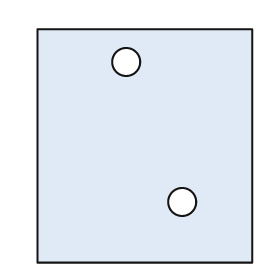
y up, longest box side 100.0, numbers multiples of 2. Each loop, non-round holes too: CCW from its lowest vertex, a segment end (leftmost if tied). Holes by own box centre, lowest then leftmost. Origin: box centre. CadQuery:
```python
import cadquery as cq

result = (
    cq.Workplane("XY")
    .moveTo(-46.0, -50.0)
    .lineTo(46.0, -50.0)
    .lineTo(46.0, 50.0)
    .lineTo(-46.0, 50.0)
    .close()
    .moveTo(16.0, -24.0)
    .circle(6.0)
    .moveTo(-8.0, 36.0)
    .circle(6.0)
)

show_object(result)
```